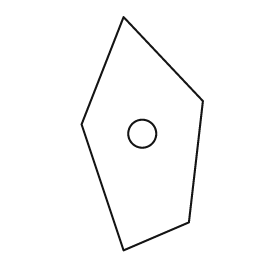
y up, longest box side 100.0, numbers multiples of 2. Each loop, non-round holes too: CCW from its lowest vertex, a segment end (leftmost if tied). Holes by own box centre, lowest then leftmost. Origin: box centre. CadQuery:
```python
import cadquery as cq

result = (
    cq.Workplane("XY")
    .moveTo(-8.0, -50.0)
    .lineTo(20.0, -38.0)
    .lineTo(26.0, 14.0)
    .lineTo(-8.0, 50.0)
    .lineTo(-26.0, 4.0)
    .close()
    .moveTo(0.0, 0.0)
    .circle(6.0)
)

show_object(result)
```